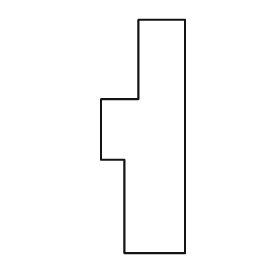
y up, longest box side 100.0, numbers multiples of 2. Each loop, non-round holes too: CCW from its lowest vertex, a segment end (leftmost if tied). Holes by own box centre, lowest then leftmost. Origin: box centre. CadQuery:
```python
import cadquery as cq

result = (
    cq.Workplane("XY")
    .moveTo(-8.0, -50.0)
    .lineTo(18.0, -50.0)
    .lineTo(18.0, 50.0)
    .lineTo(-2.0, 50.0)
    .lineTo(-2.0, 16.0)
    .lineTo(-18.0, 16.0)
    .lineTo(-18.0, -10.0)
    .lineTo(-8.0, -10.0)
    .close()
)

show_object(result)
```